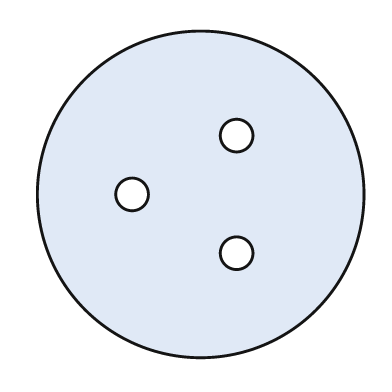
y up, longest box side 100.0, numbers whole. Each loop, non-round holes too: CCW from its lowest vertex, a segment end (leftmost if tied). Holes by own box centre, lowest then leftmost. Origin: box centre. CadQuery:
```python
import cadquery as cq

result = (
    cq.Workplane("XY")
    .moveTo(0.0, 0.0)
    .circle(50.0)
    .moveTo(11.0, -18.0)
    .circle(5.0)
    .moveTo(-21.0, 0.0)
    .circle(5.0)
    .moveTo(11.0, 18.0)
    .circle(5.0)
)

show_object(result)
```